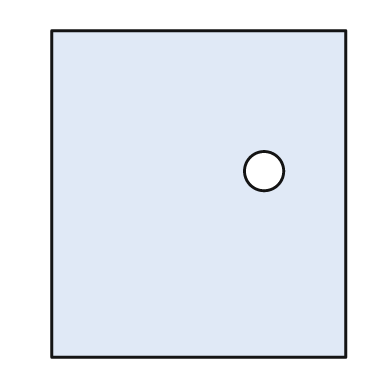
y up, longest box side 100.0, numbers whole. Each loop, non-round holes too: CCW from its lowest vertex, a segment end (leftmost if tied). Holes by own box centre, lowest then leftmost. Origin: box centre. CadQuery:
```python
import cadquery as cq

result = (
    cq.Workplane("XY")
    .moveTo(-45.0, -50.0)
    .lineTo(45.0, -50.0)
    .lineTo(45.0, 50.0)
    .lineTo(-45.0, 50.0)
    .close()
    .moveTo(20.0, 7.0)
    .circle(6.0)
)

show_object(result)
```